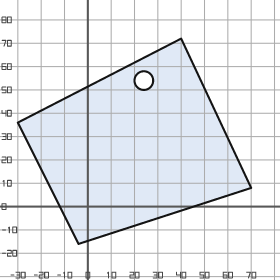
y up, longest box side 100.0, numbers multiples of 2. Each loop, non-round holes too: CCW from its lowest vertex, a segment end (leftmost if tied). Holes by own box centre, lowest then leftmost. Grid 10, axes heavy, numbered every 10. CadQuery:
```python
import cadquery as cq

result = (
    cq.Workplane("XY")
    .moveTo(-4.0, -16.0)
    .lineTo(70.0, 8.0)
    .lineTo(40.0, 72.0)
    .lineTo(-30.0, 36.0)
    .close()
    .moveTo(24.0, 54.0)
    .circle(4.0)
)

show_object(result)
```